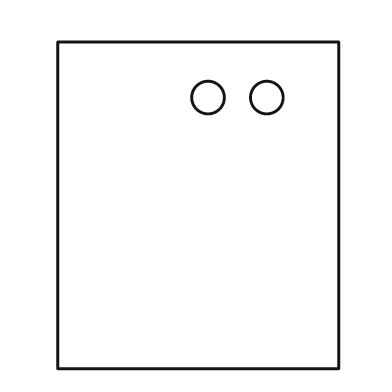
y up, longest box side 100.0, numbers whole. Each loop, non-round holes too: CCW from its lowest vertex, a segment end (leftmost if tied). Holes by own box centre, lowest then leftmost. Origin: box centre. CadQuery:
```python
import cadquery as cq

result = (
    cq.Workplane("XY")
    .moveTo(-43.0, -50.0)
    .lineTo(43.0, -50.0)
    .lineTo(43.0, 50.0)
    .lineTo(-43.0, 50.0)
    .close()
    .moveTo(3.0, 33.0)
    .circle(5.0)
    .moveTo(21.0, 33.0)
    .circle(5.0)
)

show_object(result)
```